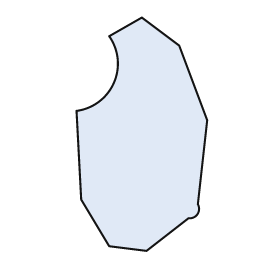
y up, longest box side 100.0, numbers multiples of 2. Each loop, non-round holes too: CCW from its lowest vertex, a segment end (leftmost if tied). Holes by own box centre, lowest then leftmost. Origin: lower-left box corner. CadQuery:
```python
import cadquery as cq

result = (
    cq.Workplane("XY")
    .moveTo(30.0, 0.0)
    .lineTo(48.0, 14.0)
    .threePointArc((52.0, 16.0), (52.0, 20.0))
    .lineTo(56.0, 56.0)
    .lineTo(44.0, 88.0)
    .lineTo(28.0, 100.0)
    .lineTo(14.0, 92.0)
    .threePointArc((16.0, 72.0), (0.0, 60.0))
    .lineTo(2.0, 22.0)
    .lineTo(14.0, 2.0)
    .close()
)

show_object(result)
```